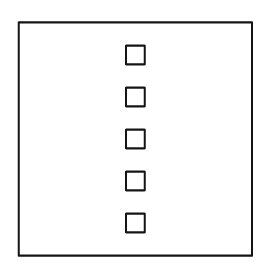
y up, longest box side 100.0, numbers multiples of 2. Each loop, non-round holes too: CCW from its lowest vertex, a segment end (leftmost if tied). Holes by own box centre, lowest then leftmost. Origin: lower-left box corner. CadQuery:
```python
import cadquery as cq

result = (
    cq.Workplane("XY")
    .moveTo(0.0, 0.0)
    .lineTo(100.0, 0.0)
    .lineTo(100.0, 100.0)
    .lineTo(0.0, 100.0)
    .close()
    .moveTo(46.0, 10.0)
    .lineTo(54.0, 10.0)
    .lineTo(54.0, 18.0)
    .lineTo(46.0, 18.0)
    .close()
    .moveTo(46.0, 28.0)
    .lineTo(54.0, 28.0)
    .lineTo(54.0, 36.0)
    .lineTo(46.0, 36.0)
    .close()
    .moveTo(46.0, 46.0)
    .lineTo(54.0, 46.0)
    .lineTo(54.0, 54.0)
    .lineTo(46.0, 54.0)
    .close()
    .moveTo(46.0, 64.0)
    .lineTo(54.0, 64.0)
    .lineTo(54.0, 72.0)
    .lineTo(46.0, 72.0)
    .close()
    .moveTo(46.0, 82.0)
    .lineTo(54.0, 82.0)
    .lineTo(54.0, 90.0)
    .lineTo(46.0, 90.0)
    .close()
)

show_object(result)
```